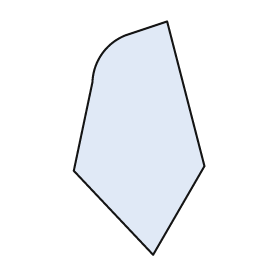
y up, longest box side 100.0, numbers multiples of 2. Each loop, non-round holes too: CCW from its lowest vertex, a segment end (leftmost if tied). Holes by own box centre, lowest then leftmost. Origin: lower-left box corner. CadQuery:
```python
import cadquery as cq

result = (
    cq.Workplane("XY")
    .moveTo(34.0, 0.0)
    .lineTo(56.0, 38.0)
    .lineTo(40.0, 100.0)
    .lineTo(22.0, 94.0)
    .threePointArc((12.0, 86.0), (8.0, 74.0))
    .lineTo(0.0, 36.0)
    .close()
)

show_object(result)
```